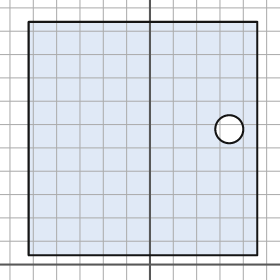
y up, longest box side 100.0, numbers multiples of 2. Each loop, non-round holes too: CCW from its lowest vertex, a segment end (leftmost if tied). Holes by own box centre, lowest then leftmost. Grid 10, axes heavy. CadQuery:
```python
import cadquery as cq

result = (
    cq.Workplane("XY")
    .moveTo(-52.0, 4.0)
    .lineTo(46.0, 4.0)
    .lineTo(46.0, 104.0)
    .lineTo(-52.0, 104.0)
    .close()
    .moveTo(34.0, 58.0)
    .circle(6.0)
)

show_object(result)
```